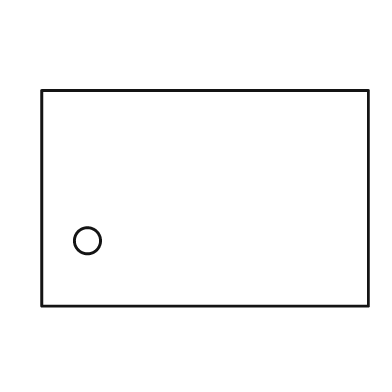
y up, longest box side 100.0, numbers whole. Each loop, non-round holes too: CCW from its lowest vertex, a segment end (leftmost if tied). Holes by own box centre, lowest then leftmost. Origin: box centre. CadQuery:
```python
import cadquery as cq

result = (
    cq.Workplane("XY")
    .moveTo(-50.0, -33.0)
    .lineTo(50.0, -33.0)
    .lineTo(50.0, 33.0)
    .lineTo(-50.0, 33.0)
    .close()
    .moveTo(-36.0, -13.0)
    .circle(4.0)
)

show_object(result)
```